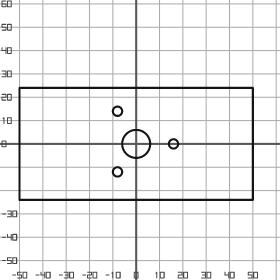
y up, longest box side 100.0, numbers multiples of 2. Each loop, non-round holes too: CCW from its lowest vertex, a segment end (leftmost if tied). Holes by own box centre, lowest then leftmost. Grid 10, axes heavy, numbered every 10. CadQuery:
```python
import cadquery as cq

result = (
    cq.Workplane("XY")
    .moveTo(-50.0, -24.0)
    .lineTo(50.0, -24.0)
    .lineTo(50.0, 24.0)
    .lineTo(-50.0, 24.0)
    .close()
    .moveTo(-8.0, -12.0)
    .circle(2.0)
    .moveTo(0.0, 0.0)
    .circle(6.0)
    .moveTo(16.0, 0.0)
    .circle(2.0)
    .moveTo(-8.0, 14.0)
    .circle(2.0)
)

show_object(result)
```